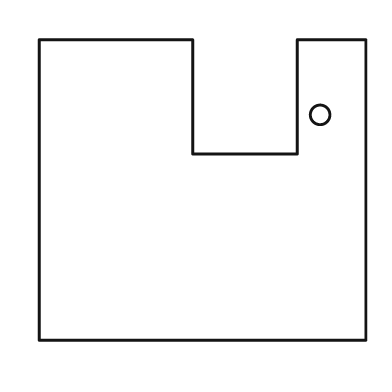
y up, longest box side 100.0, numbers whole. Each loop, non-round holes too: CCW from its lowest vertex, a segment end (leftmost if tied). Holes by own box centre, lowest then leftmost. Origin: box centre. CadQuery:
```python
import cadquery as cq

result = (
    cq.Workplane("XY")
    .moveTo(-50.0, -46.0)
    .lineTo(50.0, -46.0)
    .lineTo(50.0, 46.0)
    .lineTo(29.0, 46.0)
    .lineTo(29.0, 11.0)
    .lineTo(-3.0, 11.0)
    .lineTo(-3.0, 46.0)
    .lineTo(-50.0, 46.0)
    .close()
    .moveTo(36.0, 23.0)
    .circle(3.0)
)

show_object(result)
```